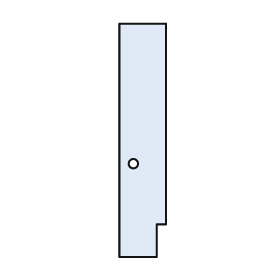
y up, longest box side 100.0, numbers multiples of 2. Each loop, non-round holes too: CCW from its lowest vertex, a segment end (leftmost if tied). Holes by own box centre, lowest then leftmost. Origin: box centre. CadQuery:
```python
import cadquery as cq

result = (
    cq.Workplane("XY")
    .moveTo(-10.0, -50.0)
    .lineTo(6.0, -50.0)
    .lineTo(6.0, -36.0)
    .lineTo(10.0, -36.0)
    .lineTo(10.0, 50.0)
    .lineTo(-10.0, 50.0)
    .close()
    .moveTo(-4.0, -10.0)
    .circle(2.0)
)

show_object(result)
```